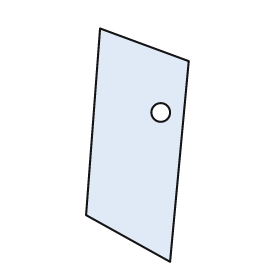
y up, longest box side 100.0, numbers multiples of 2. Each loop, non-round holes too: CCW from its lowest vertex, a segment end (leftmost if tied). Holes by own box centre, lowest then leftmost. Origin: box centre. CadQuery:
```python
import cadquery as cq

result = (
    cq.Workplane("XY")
    .moveTo(14.0, -50.0)
    .lineTo(22.0, 36.0)
    .lineTo(-16.0, 50.0)
    .lineTo(-22.0, -30.0)
    .close()
    .moveTo(10.0, 14.0)
    .circle(4.0)
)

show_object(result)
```